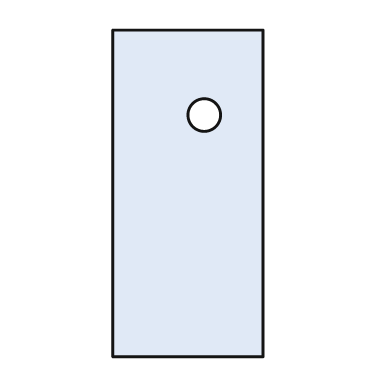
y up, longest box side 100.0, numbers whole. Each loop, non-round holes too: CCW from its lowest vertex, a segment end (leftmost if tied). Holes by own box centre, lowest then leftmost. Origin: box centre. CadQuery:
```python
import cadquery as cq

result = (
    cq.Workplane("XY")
    .moveTo(-23.0, -50.0)
    .lineTo(23.0, -50.0)
    .lineTo(23.0, 50.0)
    .lineTo(-23.0, 50.0)
    .close()
    .moveTo(5.0, 24.0)
    .circle(5.0)
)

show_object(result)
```